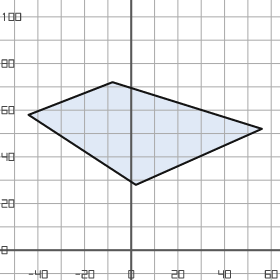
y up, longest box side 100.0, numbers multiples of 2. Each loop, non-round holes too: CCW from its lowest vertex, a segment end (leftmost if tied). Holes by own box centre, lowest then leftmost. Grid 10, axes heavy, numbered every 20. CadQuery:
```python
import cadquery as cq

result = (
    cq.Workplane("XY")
    .moveTo(2.0, 28.0)
    .lineTo(56.0, 52.0)
    .lineTo(-8.0, 72.0)
    .lineTo(-44.0, 58.0)
    .close()
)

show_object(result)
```